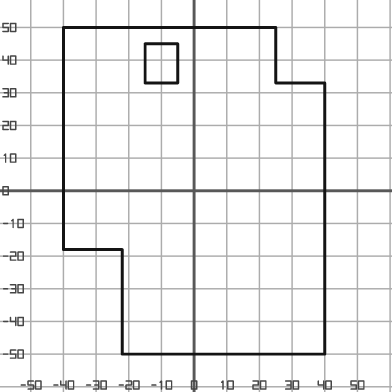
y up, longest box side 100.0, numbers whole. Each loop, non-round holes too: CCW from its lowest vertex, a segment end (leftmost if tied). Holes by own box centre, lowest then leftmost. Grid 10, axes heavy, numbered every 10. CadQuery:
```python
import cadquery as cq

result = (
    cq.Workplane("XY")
    .moveTo(-22.0, -50.0)
    .lineTo(40.0, -50.0)
    .lineTo(40.0, 33.0)
    .lineTo(25.0, 33.0)
    .lineTo(25.0, 50.0)
    .lineTo(-40.0, 50.0)
    .lineTo(-40.0, -18.0)
    .lineTo(-22.0, -18.0)
    .close()
    .moveTo(-15.0, 33.0)
    .lineTo(-5.0, 33.0)
    .lineTo(-5.0, 45.0)
    .lineTo(-15.0, 45.0)
    .close()
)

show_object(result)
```